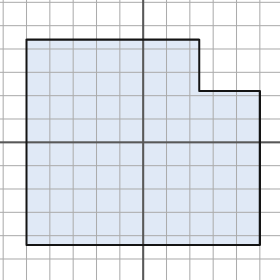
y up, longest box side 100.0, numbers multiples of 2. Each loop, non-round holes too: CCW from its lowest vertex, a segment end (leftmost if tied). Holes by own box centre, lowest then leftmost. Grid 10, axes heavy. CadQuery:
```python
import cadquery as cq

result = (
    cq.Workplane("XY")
    .moveTo(-50.0, -44.0)
    .lineTo(50.0, -44.0)
    .lineTo(50.0, 22.0)
    .lineTo(24.0, 22.0)
    .lineTo(24.0, 44.0)
    .lineTo(-50.0, 44.0)
    .close()
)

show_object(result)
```